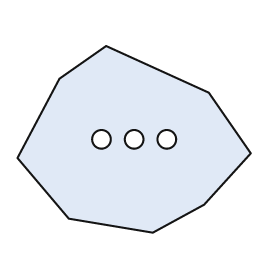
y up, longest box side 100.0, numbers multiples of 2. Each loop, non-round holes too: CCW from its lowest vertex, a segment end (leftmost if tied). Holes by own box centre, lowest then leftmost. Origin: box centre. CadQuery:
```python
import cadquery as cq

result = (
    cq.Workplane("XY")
    .moveTo(8.0, -40.0)
    .lineTo(30.0, -28.0)
    .lineTo(50.0, -6.0)
    .lineTo(32.0, 20.0)
    .lineTo(-12.0, 40.0)
    .lineTo(-32.0, 26.0)
    .lineTo(-50.0, -8.0)
    .lineTo(-28.0, -34.0)
    .close()
    .moveTo(-14.0, 0.0)
    .circle(4.0)
    .moveTo(0.0, 0.0)
    .circle(4.0)
    .moveTo(14.0, 0.0)
    .circle(4.0)
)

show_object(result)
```